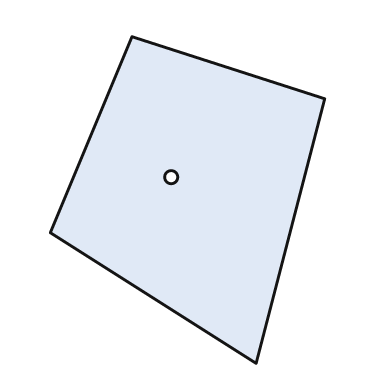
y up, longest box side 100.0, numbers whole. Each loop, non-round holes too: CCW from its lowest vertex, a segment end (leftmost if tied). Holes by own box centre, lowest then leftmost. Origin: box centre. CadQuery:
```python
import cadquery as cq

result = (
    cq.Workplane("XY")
    .moveTo(21.0, -50.0)
    .lineTo(42.0, 31.0)
    .lineTo(-17.0, 50.0)
    .lineTo(-42.0, -10.0)
    .close()
    .moveTo(-5.0, 7.0)
    .circle(2.0)
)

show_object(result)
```